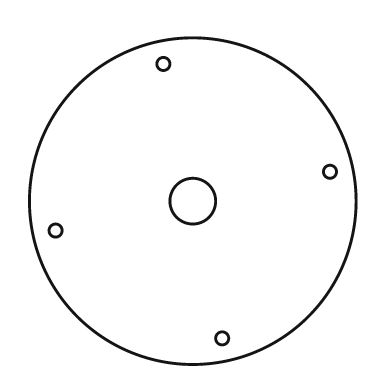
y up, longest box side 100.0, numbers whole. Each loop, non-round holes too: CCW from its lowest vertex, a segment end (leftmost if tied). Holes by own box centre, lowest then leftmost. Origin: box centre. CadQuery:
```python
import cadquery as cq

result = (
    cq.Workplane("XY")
    .moveTo(0.0, 0.0)
    .circle(50.0)
    .moveTo(9.0, -42.0)
    .circle(2.0)
    .moveTo(-42.0, -9.0)
    .circle(2.0)
    .moveTo(0.0, 0.0)
    .circle(7.0)
    .moveTo(42.0, 9.0)
    .circle(2.0)
    .moveTo(-9.0, 42.0)
    .circle(2.0)
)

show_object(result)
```